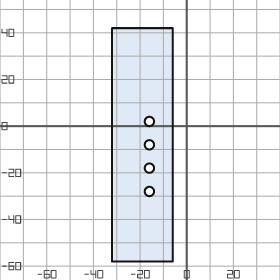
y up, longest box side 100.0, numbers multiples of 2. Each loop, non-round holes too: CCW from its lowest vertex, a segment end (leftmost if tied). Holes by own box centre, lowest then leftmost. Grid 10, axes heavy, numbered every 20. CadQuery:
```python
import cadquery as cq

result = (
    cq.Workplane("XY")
    .moveTo(-32.0, -58.0)
    .lineTo(-6.0, -58.0)
    .lineTo(-6.0, 42.0)
    .lineTo(-32.0, 42.0)
    .close()
    .moveTo(-16.0, -28.0)
    .circle(2.0)
    .moveTo(-16.0, -18.0)
    .circle(2.0)
    .moveTo(-16.0, -8.0)
    .circle(2.0)
    .moveTo(-16.0, 2.0)
    .circle(2.0)
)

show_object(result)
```